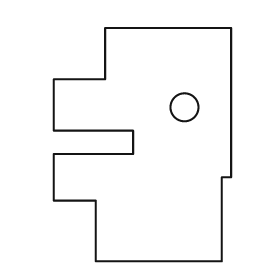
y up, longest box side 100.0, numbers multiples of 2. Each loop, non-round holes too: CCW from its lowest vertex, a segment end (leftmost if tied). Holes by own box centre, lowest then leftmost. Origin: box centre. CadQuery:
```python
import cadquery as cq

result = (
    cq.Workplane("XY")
    .moveTo(-20.0, -50.0)
    .lineTo(34.0, -50.0)
    .lineTo(34.0, -14.0)
    .lineTo(38.0, -14.0)
    .lineTo(38.0, 50.0)
    .lineTo(-16.0, 50.0)
    .lineTo(-16.0, 28.0)
    .lineTo(-38.0, 28.0)
    .lineTo(-38.0, 6.0)
    .lineTo(-4.0, 6.0)
    .lineTo(-4.0, -4.0)
    .lineTo(-38.0, -4.0)
    .lineTo(-38.0, -24.0)
    .lineTo(-20.0, -24.0)
    .close()
    .moveTo(18.0, 16.0)
    .circle(6.0)
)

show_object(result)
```